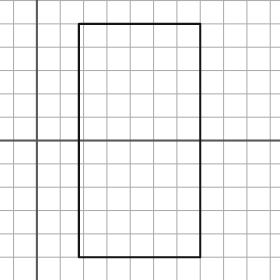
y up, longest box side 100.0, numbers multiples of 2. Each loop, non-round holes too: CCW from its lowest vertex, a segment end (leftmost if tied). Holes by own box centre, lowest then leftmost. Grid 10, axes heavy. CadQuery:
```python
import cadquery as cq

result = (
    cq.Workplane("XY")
    .moveTo(18.0, -50.0)
    .lineTo(70.0, -50.0)
    .lineTo(70.0, 50.0)
    .lineTo(18.0, 50.0)
    .close()
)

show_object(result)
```